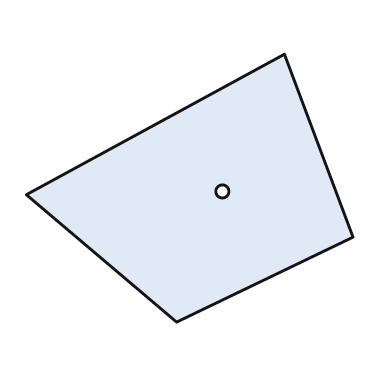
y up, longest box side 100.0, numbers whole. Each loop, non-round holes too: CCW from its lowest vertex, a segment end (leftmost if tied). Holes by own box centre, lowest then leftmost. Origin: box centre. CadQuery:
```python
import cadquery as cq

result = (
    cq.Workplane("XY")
    .moveTo(-4.0, -41.0)
    .lineTo(50.0, -15.0)
    .lineTo(29.0, 41.0)
    .lineTo(-50.0, -2.0)
    .close()
    .moveTo(10.0, -1.0)
    .circle(2.0)
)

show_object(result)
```